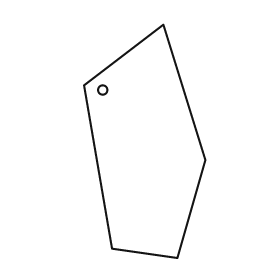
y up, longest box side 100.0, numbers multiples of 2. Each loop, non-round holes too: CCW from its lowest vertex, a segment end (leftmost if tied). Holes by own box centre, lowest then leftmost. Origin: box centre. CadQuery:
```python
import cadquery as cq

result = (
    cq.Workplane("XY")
    .moveTo(14.0, -50.0)
    .lineTo(26.0, -8.0)
    .lineTo(8.0, 50.0)
    .lineTo(-26.0, 24.0)
    .lineTo(-14.0, -46.0)
    .close()
    .moveTo(-18.0, 22.0)
    .circle(2.0)
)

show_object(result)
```